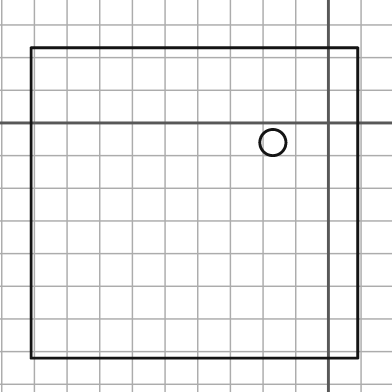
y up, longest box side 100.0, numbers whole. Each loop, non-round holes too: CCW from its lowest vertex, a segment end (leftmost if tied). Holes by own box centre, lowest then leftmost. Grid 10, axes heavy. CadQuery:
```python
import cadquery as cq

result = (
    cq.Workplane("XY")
    .moveTo(-91.0, -72.0)
    .lineTo(9.0, -72.0)
    .lineTo(9.0, 23.0)
    .lineTo(-91.0, 23.0)
    .close()
    .moveTo(-17.0, -6.0)
    .circle(4.0)
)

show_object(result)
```